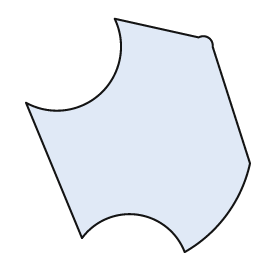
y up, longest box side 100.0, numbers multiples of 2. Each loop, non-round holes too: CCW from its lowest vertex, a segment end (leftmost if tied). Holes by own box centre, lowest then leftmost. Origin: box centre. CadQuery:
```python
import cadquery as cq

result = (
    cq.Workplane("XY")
    .moveTo(20.0, -50.0)
    .threePointArc((38.0, -34.0), (48.0, -12.0))
    .lineTo(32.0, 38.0)
    .threePointArc((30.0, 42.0), (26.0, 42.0))
    .lineTo(-10.0, 50.0)
    .threePointArc((-16.0, 18.0), (-48.0, 14.0))
    .lineTo(-24.0, -44.0)
    .threePointArc((0.0, -34.0), (20.0, -50.0))
    .close()
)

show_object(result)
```